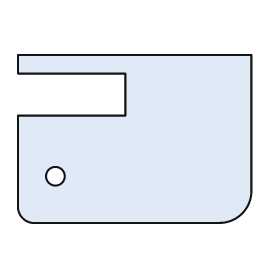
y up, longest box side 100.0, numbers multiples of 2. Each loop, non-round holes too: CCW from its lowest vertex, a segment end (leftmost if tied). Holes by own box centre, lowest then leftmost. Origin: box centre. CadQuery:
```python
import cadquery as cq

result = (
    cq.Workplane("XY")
    .moveTo(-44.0, -36.0)
    .lineTo(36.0, -36.0)
    .threePointArc((46.0, -32.0), (50.0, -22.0))
    .lineTo(50.0, 36.0)
    .lineTo(-50.0, 36.0)
    .lineTo(-50.0, 28.0)
    .lineTo(-4.0, 28.0)
    .lineTo(-4.0, 10.0)
    .lineTo(-50.0, 10.0)
    .lineTo(-50.0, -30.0)
    .threePointArc((-48.0, -34.0), (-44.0, -36.0))
    .close()
    .moveTo(-34.0, -16.0)
    .circle(4.0)
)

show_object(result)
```